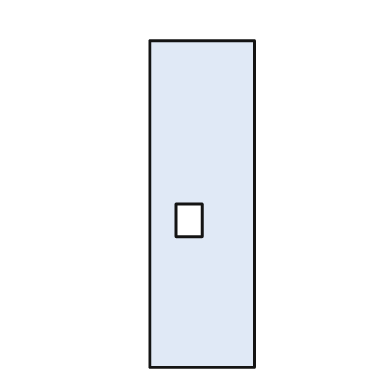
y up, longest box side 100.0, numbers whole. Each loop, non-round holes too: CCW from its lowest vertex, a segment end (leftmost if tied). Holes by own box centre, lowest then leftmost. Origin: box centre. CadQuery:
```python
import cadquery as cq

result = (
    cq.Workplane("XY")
    .moveTo(-16.0, -50.0)
    .lineTo(16.0, -50.0)
    .lineTo(16.0, 50.0)
    .lineTo(-16.0, 50.0)
    .close()
    .moveTo(-8.0, -10.0)
    .lineTo(0.0, -10.0)
    .lineTo(0.0, 0.0)
    .lineTo(-8.0, 0.0)
    .close()
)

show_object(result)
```